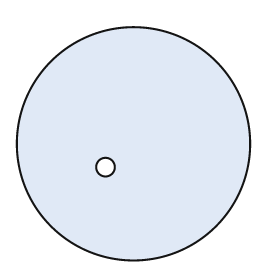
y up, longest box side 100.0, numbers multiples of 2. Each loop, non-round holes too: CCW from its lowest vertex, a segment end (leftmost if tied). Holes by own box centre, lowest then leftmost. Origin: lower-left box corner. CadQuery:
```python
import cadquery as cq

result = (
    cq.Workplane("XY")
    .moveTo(50.0, 50.0)
    .circle(50.0)
    .moveTo(38.0, 40.0)
    .circle(4.0)
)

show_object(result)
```